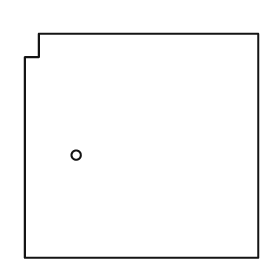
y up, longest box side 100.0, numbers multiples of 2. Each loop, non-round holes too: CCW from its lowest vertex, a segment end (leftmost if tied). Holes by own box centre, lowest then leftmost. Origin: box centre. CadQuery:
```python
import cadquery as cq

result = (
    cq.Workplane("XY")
    .moveTo(-50.0, -48.0)
    .lineTo(50.0, -48.0)
    .lineTo(50.0, 48.0)
    .lineTo(-44.0, 48.0)
    .lineTo(-44.0, 38.0)
    .lineTo(-50.0, 38.0)
    .close()
    .moveTo(-28.0, -4.0)
    .circle(2.0)
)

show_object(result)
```